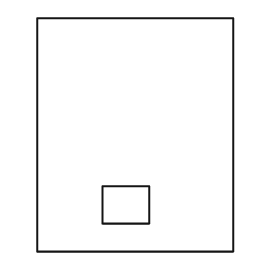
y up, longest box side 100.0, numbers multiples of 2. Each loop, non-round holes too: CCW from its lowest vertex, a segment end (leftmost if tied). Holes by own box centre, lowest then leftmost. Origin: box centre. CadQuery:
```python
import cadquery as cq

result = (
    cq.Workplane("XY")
    .moveTo(-42.0, -50.0)
    .lineTo(42.0, -50.0)
    .lineTo(42.0, 50.0)
    .lineTo(-42.0, 50.0)
    .close()
    .moveTo(-14.0, -38.0)
    .lineTo(6.0, -38.0)
    .lineTo(6.0, -22.0)
    .lineTo(-14.0, -22.0)
    .close()
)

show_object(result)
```